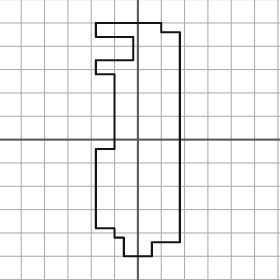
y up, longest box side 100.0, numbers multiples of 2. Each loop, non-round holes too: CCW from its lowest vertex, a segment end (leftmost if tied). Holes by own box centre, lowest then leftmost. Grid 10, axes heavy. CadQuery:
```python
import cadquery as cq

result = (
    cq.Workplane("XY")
    .moveTo(-6.0, -50.0)
    .lineTo(6.0, -50.0)
    .lineTo(6.0, -44.0)
    .lineTo(18.0, -44.0)
    .lineTo(18.0, 46.0)
    .lineTo(10.0, 46.0)
    .lineTo(10.0, 50.0)
    .lineTo(-18.0, 50.0)
    .lineTo(-18.0, 44.0)
    .lineTo(-2.0, 44.0)
    .lineTo(-2.0, 34.0)
    .lineTo(-18.0, 34.0)
    .lineTo(-18.0, 28.0)
    .lineTo(-10.0, 28.0)
    .lineTo(-10.0, -4.0)
    .lineTo(-18.0, -4.0)
    .lineTo(-18.0, -38.0)
    .lineTo(-10.0, -38.0)
    .lineTo(-10.0, -42.0)
    .lineTo(-6.0, -42.0)
    .close()
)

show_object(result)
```